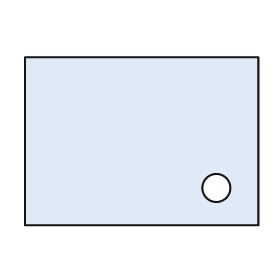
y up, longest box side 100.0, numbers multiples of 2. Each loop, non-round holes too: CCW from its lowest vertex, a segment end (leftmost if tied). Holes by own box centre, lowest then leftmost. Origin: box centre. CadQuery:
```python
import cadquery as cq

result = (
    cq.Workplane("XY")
    .moveTo(-50.0, -36.0)
    .lineTo(50.0, -36.0)
    .lineTo(50.0, 36.0)
    .lineTo(-50.0, 36.0)
    .close()
    .moveTo(32.0, -20.0)
    .circle(6.0)
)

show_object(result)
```